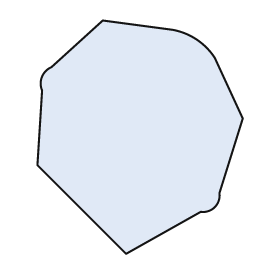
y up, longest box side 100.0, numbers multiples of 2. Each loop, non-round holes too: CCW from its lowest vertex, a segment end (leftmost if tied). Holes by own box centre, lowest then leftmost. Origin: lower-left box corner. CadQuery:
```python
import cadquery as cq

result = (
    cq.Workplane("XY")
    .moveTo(38.0, 0.0)
    .lineTo(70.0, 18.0)
    .threePointArc((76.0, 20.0), (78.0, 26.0))
    .lineTo(88.0, 58.0)
    .lineTo(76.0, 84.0)
    .threePointArc((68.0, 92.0), (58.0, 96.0))
    .lineTo(28.0, 100.0)
    .lineTo(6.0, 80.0)
    .threePointArc((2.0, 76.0), (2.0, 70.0))
    .lineTo(0.0, 38.0)
    .close()
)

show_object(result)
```